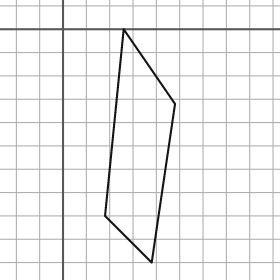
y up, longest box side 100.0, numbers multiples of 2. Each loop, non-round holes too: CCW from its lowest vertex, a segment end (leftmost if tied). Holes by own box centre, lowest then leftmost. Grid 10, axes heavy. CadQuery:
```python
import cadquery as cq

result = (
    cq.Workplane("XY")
    .moveTo(38.0, -100.0)
    .lineTo(48.0, -32.0)
    .lineTo(26.0, 0.0)
    .lineTo(18.0, -80.0)
    .close()
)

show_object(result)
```